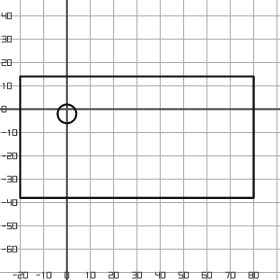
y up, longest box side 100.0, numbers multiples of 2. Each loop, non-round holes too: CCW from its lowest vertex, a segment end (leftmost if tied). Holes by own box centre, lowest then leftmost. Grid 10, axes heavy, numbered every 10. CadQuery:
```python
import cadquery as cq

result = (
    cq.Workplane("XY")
    .moveTo(-20.0, -38.0)
    .lineTo(80.0, -38.0)
    .lineTo(80.0, 14.0)
    .lineTo(-20.0, 14.0)
    .close()
    .moveTo(0.0, -2.0)
    .circle(4.0)
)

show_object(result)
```